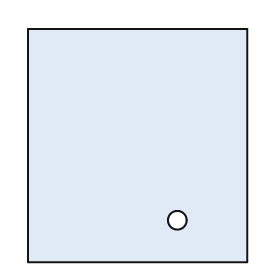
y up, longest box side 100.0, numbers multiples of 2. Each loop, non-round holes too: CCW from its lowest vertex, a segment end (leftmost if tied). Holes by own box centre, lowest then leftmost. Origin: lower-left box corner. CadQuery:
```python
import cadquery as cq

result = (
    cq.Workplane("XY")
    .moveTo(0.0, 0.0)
    .lineTo(94.0, 0.0)
    .lineTo(94.0, 100.0)
    .lineTo(0.0, 100.0)
    .close()
    .moveTo(64.0, 18.0)
    .circle(4.0)
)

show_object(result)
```